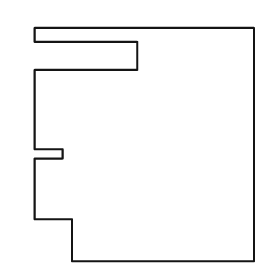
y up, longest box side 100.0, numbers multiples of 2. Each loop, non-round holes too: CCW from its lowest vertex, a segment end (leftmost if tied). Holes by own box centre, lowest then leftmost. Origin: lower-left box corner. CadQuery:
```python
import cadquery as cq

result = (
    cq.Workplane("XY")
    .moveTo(16.0, 0.0)
    .lineTo(94.0, 0.0)
    .lineTo(94.0, 100.0)
    .lineTo(0.0, 100.0)
    .lineTo(0.0, 94.0)
    .lineTo(44.0, 94.0)
    .lineTo(44.0, 82.0)
    .lineTo(0.0, 82.0)
    .lineTo(0.0, 48.0)
    .lineTo(12.0, 48.0)
    .lineTo(12.0, 44.0)
    .lineTo(0.0, 44.0)
    .lineTo(0.0, 18.0)
    .lineTo(16.0, 18.0)
    .close()
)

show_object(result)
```